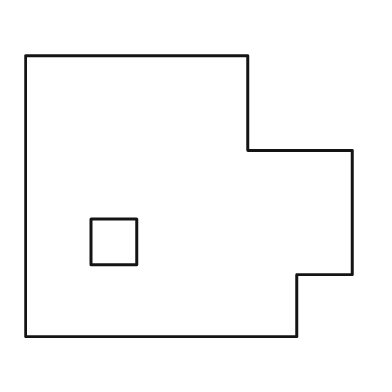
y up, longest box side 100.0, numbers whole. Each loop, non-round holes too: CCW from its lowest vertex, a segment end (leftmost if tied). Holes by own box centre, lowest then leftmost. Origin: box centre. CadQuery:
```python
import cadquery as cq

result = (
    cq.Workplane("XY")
    .moveTo(-50.0, -43.0)
    .lineTo(33.0, -43.0)
    .lineTo(33.0, -24.0)
    .lineTo(50.0, -24.0)
    .lineTo(50.0, 14.0)
    .lineTo(18.0, 14.0)
    .lineTo(18.0, 43.0)
    .lineTo(-50.0, 43.0)
    .close()
    .moveTo(-30.0, -21.0)
    .lineTo(-16.0, -21.0)
    .lineTo(-16.0, -7.0)
    .lineTo(-30.0, -7.0)
    .close()
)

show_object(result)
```